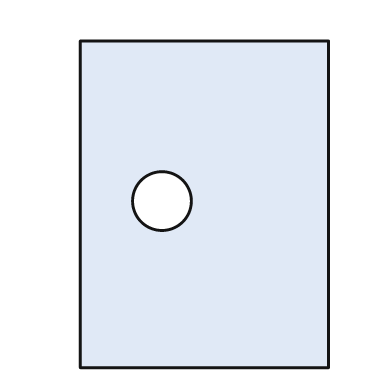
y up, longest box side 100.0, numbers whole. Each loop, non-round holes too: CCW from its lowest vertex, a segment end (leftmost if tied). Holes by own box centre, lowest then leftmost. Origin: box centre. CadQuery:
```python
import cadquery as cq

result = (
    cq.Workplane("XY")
    .moveTo(-38.0, -50.0)
    .lineTo(38.0, -50.0)
    .lineTo(38.0, 50.0)
    .lineTo(-38.0, 50.0)
    .close()
    .moveTo(-13.0, 1.0)
    .circle(9.0)
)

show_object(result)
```